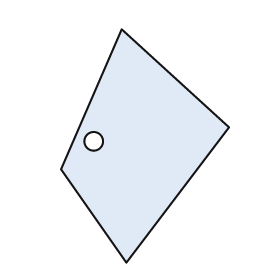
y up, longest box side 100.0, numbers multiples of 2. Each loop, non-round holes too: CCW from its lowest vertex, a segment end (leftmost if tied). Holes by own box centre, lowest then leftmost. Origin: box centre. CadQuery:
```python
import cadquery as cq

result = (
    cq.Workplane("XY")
    .moveTo(-8.0, -50.0)
    .lineTo(36.0, 8.0)
    .lineTo(-10.0, 50.0)
    .lineTo(-36.0, -10.0)
    .close()
    .moveTo(-22.0, 2.0)
    .circle(4.0)
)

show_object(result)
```